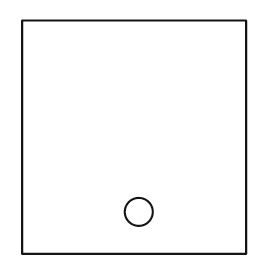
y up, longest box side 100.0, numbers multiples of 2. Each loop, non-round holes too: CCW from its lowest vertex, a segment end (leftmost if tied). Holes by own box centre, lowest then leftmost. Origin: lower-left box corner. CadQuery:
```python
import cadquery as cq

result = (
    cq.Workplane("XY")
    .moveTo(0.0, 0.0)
    .lineTo(96.0, 0.0)
    .lineTo(96.0, 100.0)
    .lineTo(0.0, 100.0)
    .close()
    .moveTo(50.0, 18.0)
    .circle(6.0)
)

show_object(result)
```